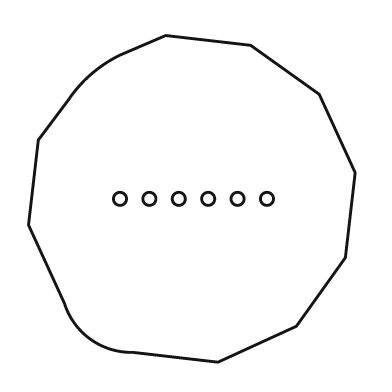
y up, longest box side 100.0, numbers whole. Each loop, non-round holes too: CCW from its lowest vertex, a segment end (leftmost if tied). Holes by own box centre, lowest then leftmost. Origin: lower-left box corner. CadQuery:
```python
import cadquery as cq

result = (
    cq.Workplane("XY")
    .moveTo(58.0, 0.0)
    .lineTo(82.0, 11.0)
    .lineTo(97.0, 32.0)
    .lineTo(100.0, 58.0)
    .lineTo(89.0, 82.0)
    .lineTo(68.0, 97.0)
    .lineTo(42.0, 100.0)
    .lineTo(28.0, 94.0)
    .threePointArc((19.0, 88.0), (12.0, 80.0))
    .lineTo(3.0, 68.0)
    .lineTo(0.0, 42.0)
    .lineTo(11.0, 18.0)
    .threePointArc((19.0, 7.0), (32.0, 3.0))
    .close()
    .moveTo(28.0, 50.0)
    .circle(2.0)
    .moveTo(37.0, 50.0)
    .circle(2.0)
    .moveTo(46.0, 50.0)
    .circle(2.0)
    .moveTo(55.0, 50.0)
    .circle(2.0)
    .moveTo(64.0, 50.0)
    .circle(2.0)
    .moveTo(73.0, 50.0)
    .circle(2.0)
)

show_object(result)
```